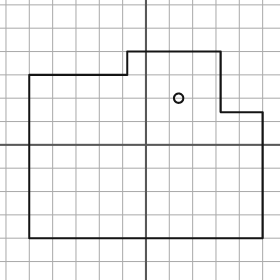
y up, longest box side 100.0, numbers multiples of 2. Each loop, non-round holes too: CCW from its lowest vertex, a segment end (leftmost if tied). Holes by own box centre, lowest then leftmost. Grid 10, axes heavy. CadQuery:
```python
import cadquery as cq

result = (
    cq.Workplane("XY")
    .moveTo(-50.0, -40.0)
    .lineTo(50.0, -40.0)
    .lineTo(50.0, 14.0)
    .lineTo(32.0, 14.0)
    .lineTo(32.0, 40.0)
    .lineTo(-8.0, 40.0)
    .lineTo(-8.0, 30.0)
    .lineTo(-50.0, 30.0)
    .close()
    .moveTo(14.0, 20.0)
    .circle(2.0)
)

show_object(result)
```